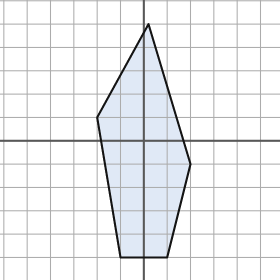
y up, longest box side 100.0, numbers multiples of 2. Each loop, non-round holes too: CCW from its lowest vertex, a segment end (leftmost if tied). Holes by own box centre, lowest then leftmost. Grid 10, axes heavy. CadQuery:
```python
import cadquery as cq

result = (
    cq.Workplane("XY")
    .moveTo(-10.0, -50.0)
    .lineTo(10.0, -50.0)
    .lineTo(20.0, -10.0)
    .lineTo(2.0, 50.0)
    .lineTo(-20.0, 10.0)
    .close()
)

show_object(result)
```